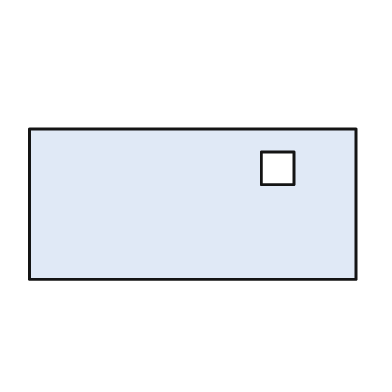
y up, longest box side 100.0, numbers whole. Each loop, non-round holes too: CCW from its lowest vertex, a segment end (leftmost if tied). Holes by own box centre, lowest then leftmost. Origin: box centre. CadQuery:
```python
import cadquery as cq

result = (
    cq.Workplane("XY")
    .moveTo(-50.0, -23.0)
    .lineTo(50.0, -23.0)
    .lineTo(50.0, 23.0)
    .lineTo(-50.0, 23.0)
    .close()
    .moveTo(21.0, 6.0)
    .lineTo(31.0, 6.0)
    .lineTo(31.0, 16.0)
    .lineTo(21.0, 16.0)
    .close()
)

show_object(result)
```